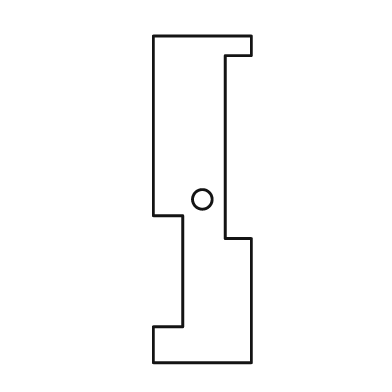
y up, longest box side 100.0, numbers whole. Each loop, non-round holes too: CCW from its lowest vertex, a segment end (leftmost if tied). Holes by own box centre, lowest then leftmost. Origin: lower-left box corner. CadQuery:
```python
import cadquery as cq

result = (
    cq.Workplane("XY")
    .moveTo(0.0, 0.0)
    .lineTo(30.0, 0.0)
    .lineTo(30.0, 38.0)
    .lineTo(22.0, 38.0)
    .lineTo(22.0, 94.0)
    .lineTo(30.0, 94.0)
    .lineTo(30.0, 100.0)
    .lineTo(0.0, 100.0)
    .lineTo(0.0, 45.0)
    .lineTo(9.0, 45.0)
    .lineTo(9.0, 11.0)
    .lineTo(0.0, 11.0)
    .close()
    .moveTo(15.0, 50.0)
    .circle(3.0)
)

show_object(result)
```